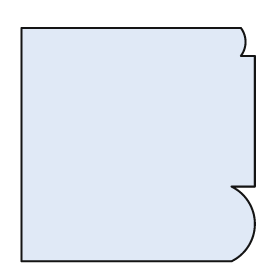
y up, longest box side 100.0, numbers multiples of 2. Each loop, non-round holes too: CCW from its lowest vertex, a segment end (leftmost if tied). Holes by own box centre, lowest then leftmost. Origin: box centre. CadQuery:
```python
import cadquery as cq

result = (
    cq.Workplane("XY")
    .moveTo(-50.0, -50.0)
    .lineTo(40.0, -50.0)
    .threePointArc((50.0, -34.0), (40.0, -18.0))
    .lineTo(50.0, -18.0)
    .lineTo(50.0, 38.0)
    .lineTo(44.0, 38.0)
    .threePointArc((46.0, 44.0), (44.0, 50.0))
    .lineTo(-50.0, 50.0)
    .close()
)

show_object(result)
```